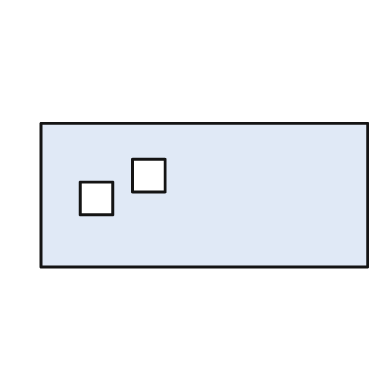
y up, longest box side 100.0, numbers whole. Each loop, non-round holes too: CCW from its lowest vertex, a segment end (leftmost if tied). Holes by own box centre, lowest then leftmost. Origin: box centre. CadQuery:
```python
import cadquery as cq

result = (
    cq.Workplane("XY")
    .moveTo(-50.0, -22.0)
    .lineTo(50.0, -22.0)
    .lineTo(50.0, 22.0)
    .lineTo(-50.0, 22.0)
    .close()
    .moveTo(-38.0, -6.0)
    .lineTo(-28.0, -6.0)
    .lineTo(-28.0, 4.0)
    .lineTo(-38.0, 4.0)
    .close()
    .moveTo(-22.0, 1.0)
    .lineTo(-12.0, 1.0)
    .lineTo(-12.0, 11.0)
    .lineTo(-22.0, 11.0)
    .close()
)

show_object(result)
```